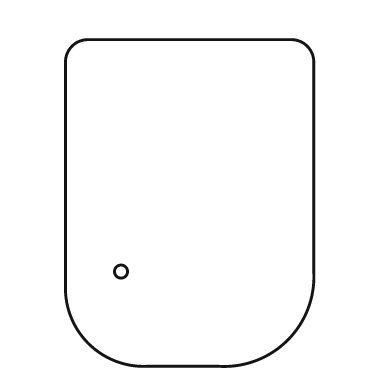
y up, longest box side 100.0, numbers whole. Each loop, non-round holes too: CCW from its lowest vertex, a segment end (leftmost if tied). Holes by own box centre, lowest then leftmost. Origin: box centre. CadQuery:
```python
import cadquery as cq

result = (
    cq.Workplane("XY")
    .moveTo(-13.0, -50.0)
    .lineTo(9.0, -50.0)
    .threePointArc((30.0, -42.0), (38.0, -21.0))
    .lineTo(38.0, 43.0)
    .threePointArc((36.0, 48.0), (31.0, 50.0))
    .lineTo(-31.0, 50.0)
    .threePointArc((-36.0, 48.0), (-38.0, 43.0))
    .lineTo(-38.0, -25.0)
    .threePointArc((-31.0, -43.0), (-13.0, -50.0))
    .close()
    .moveTo(-21.0, -21.0)
    .circle(2.0)
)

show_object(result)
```